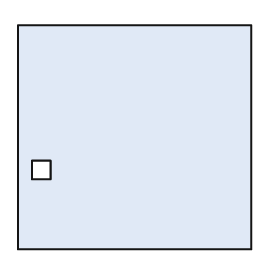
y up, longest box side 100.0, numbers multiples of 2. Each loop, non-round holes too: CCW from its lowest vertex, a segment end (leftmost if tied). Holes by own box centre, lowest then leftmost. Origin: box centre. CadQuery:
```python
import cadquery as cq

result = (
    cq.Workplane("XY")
    .moveTo(-50.0, -48.0)
    .lineTo(50.0, -48.0)
    .lineTo(50.0, 48.0)
    .lineTo(-50.0, 48.0)
    .close()
    .moveTo(-44.0, -18.0)
    .lineTo(-36.0, -18.0)
    .lineTo(-36.0, -10.0)
    .lineTo(-44.0, -10.0)
    .close()
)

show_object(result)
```